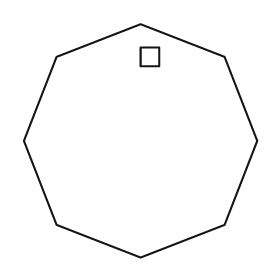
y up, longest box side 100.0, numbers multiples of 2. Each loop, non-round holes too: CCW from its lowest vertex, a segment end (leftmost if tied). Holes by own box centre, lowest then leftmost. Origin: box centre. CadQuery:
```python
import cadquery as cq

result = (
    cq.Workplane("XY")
    .moveTo(0.0, -50.0)
    .lineTo(36.0, -36.0)
    .lineTo(50.0, 0.0)
    .lineTo(36.0, 36.0)
    .lineTo(0.0, 50.0)
    .lineTo(-36.0, 36.0)
    .lineTo(-50.0, 0.0)
    .lineTo(-36.0, -36.0)
    .close()
    .moveTo(0.0, 32.0)
    .lineTo(8.0, 32.0)
    .lineTo(8.0, 40.0)
    .lineTo(0.0, 40.0)
    .close()
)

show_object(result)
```